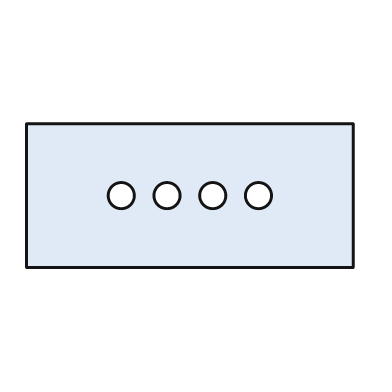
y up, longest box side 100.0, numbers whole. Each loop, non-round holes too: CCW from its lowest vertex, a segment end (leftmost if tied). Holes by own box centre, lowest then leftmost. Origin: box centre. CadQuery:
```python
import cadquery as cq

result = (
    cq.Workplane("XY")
    .moveTo(-50.0, -22.0)
    .lineTo(50.0, -22.0)
    .lineTo(50.0, 22.0)
    .lineTo(-50.0, 22.0)
    .close()
    .moveTo(-21.0, 0.0)
    .circle(4.0)
    .moveTo(-7.0, 0.0)
    .circle(4.0)
    .moveTo(7.0, 0.0)
    .circle(4.0)
    .moveTo(21.0, 0.0)
    .circle(4.0)
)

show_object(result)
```